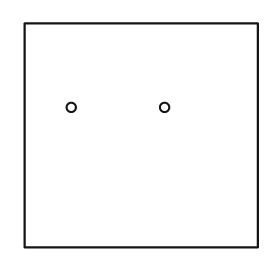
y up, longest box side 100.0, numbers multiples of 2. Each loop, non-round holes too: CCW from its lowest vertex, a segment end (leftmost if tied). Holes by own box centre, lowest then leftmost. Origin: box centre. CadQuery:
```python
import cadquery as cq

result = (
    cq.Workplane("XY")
    .moveTo(-50.0, -48.0)
    .lineTo(50.0, -48.0)
    .lineTo(50.0, 48.0)
    .lineTo(-50.0, 48.0)
    .close()
    .moveTo(-30.0, 12.0)
    .circle(2.0)
    .moveTo(10.0, 12.0)
    .circle(2.0)
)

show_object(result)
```